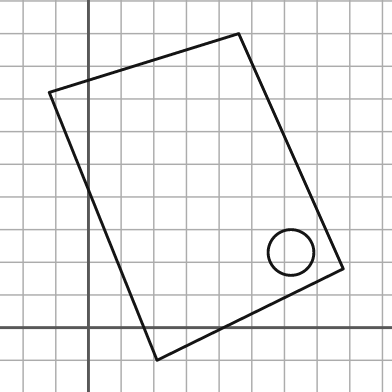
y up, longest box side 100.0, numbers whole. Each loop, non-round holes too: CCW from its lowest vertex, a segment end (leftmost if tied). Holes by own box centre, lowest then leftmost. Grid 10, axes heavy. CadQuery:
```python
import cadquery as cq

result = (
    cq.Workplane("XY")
    .moveTo(21.0, -10.0)
    .lineTo(78.0, 18.0)
    .lineTo(46.0, 90.0)
    .lineTo(-12.0, 72.0)
    .close()
    .moveTo(62.0, 23.0)
    .circle(7.0)
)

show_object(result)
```